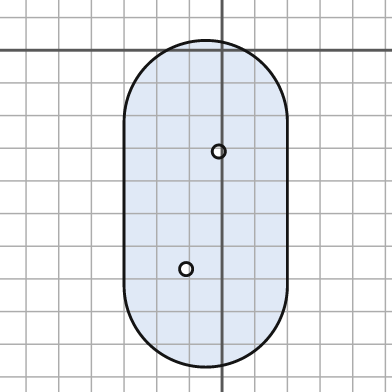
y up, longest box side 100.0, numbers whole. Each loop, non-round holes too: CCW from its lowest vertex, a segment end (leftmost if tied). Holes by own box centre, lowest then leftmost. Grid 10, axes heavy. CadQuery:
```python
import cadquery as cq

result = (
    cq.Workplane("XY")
    .moveTo(-30.0, -72.0)
    .threePointArc((-5.0, -97.0), (20.0, -72.0))
    .lineTo(20.0, -22.0)
    .threePointArc((-5.0, 3.0), (-30.0, -22.0))
    .close()
    .moveTo(-11.0, -67.0)
    .circle(2.0)
    .moveTo(-1.0, -31.0)
    .circle(2.0)
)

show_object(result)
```